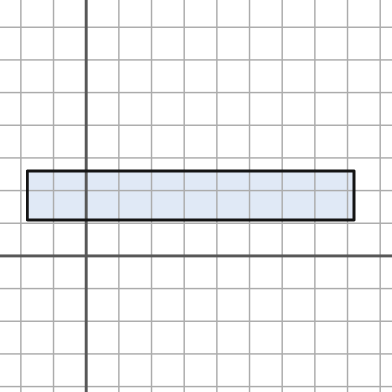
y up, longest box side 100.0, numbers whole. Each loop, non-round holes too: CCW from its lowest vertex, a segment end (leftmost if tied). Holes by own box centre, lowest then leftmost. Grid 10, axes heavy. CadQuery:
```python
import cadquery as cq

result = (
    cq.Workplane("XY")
    .moveTo(-18.0, 11.0)
    .lineTo(82.0, 11.0)
    .lineTo(82.0, 26.0)
    .lineTo(-18.0, 26.0)
    .close()
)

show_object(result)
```